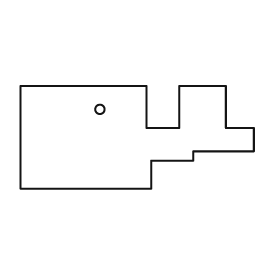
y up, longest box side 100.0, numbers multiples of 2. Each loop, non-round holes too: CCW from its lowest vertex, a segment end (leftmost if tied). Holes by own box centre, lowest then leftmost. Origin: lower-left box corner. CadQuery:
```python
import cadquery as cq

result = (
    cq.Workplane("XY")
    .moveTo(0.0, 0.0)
    .lineTo(56.0, 0.0)
    .lineTo(56.0, 12.0)
    .lineTo(74.0, 12.0)
    .lineTo(74.0, 16.0)
    .lineTo(100.0, 16.0)
    .lineTo(100.0, 26.0)
    .lineTo(88.0, 26.0)
    .lineTo(88.0, 44.0)
    .lineTo(68.0, 44.0)
    .lineTo(68.0, 26.0)
    .lineTo(54.0, 26.0)
    .lineTo(54.0, 44.0)
    .lineTo(0.0, 44.0)
    .close()
    .moveTo(34.0, 34.0)
    .circle(2.0)
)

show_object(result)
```